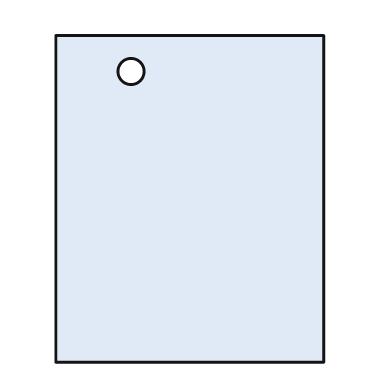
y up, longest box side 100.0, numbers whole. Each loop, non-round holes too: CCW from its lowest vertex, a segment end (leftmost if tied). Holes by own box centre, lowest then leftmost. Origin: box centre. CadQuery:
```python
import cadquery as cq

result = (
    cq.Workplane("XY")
    .moveTo(-41.0, -50.0)
    .lineTo(41.0, -50.0)
    .lineTo(41.0, 50.0)
    .lineTo(-41.0, 50.0)
    .close()
    .moveTo(-18.0, 39.0)
    .circle(4.0)
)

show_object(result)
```